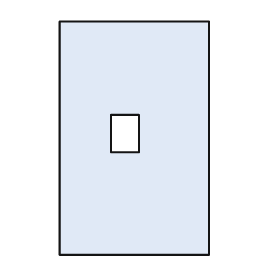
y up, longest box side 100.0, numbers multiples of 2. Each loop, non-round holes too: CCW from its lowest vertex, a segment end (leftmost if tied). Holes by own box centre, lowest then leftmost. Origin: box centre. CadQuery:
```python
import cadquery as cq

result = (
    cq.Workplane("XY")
    .moveTo(-32.0, -50.0)
    .lineTo(32.0, -50.0)
    .lineTo(32.0, 50.0)
    .lineTo(-32.0, 50.0)
    .close()
    .moveTo(-10.0, -6.0)
    .lineTo(2.0, -6.0)
    .lineTo(2.0, 10.0)
    .lineTo(-10.0, 10.0)
    .close()
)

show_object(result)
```